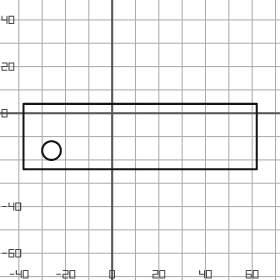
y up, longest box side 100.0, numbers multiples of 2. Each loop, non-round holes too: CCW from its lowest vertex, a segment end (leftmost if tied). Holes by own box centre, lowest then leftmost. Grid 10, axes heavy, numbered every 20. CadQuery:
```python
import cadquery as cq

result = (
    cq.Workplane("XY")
    .moveTo(-38.0, -24.0)
    .lineTo(62.0, -24.0)
    .lineTo(62.0, 4.0)
    .lineTo(-38.0, 4.0)
    .close()
    .moveTo(-26.0, -16.0)
    .circle(4.0)
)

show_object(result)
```